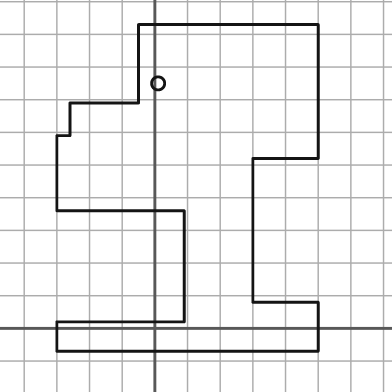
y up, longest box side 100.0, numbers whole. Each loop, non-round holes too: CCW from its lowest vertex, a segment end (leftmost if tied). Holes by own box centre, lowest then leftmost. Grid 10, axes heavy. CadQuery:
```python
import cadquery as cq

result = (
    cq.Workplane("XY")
    .moveTo(-30.0, -7.0)
    .lineTo(50.0, -7.0)
    .lineTo(50.0, 8.0)
    .lineTo(30.0, 8.0)
    .lineTo(30.0, 52.0)
    .lineTo(50.0, 52.0)
    .lineTo(50.0, 93.0)
    .lineTo(-5.0, 93.0)
    .lineTo(-5.0, 69.0)
    .lineTo(-26.0, 69.0)
    .lineTo(-26.0, 59.0)
    .lineTo(-30.0, 59.0)
    .lineTo(-30.0, 36.0)
    .lineTo(9.0, 36.0)
    .lineTo(9.0, 2.0)
    .lineTo(-30.0, 2.0)
    .close()
    .moveTo(1.0, 75.0)
    .circle(2.0)
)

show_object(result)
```